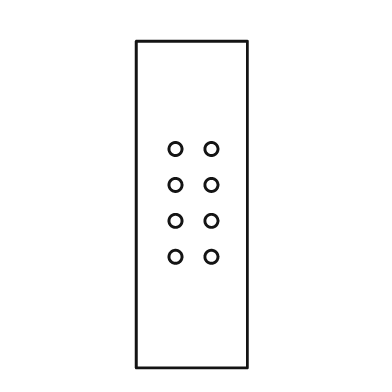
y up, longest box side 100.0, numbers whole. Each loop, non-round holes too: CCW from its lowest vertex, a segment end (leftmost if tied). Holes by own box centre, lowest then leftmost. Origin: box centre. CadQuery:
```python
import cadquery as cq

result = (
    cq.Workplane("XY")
    .moveTo(-17.0, -50.0)
    .lineTo(17.0, -50.0)
    .lineTo(17.0, 50.0)
    .lineTo(-17.0, 50.0)
    .close()
    .moveTo(-5.0, -16.0)
    .circle(2.0)
    .moveTo(6.0, -16.0)
    .circle(2.0)
    .moveTo(-5.0, -5.0)
    .circle(2.0)
    .moveTo(6.0, -5.0)
    .circle(2.0)
    .moveTo(-5.0, 6.0)
    .circle(2.0)
    .moveTo(6.0, 6.0)
    .circle(2.0)
    .moveTo(-5.0, 17.0)
    .circle(2.0)
    .moveTo(6.0, 17.0)
    .circle(2.0)
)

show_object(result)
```